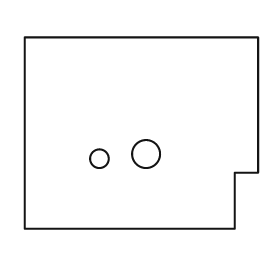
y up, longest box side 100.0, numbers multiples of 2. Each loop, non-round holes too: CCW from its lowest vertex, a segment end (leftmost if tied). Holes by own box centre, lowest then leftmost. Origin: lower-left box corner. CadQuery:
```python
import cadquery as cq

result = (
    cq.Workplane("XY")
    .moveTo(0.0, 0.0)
    .lineTo(90.0, 0.0)
    .lineTo(90.0, 24.0)
    .lineTo(100.0, 24.0)
    .lineTo(100.0, 82.0)
    .lineTo(0.0, 82.0)
    .close()
    .moveTo(32.0, 30.0)
    .circle(4.0)
    .moveTo(52.0, 32.0)
    .circle(6.0)
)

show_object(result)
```